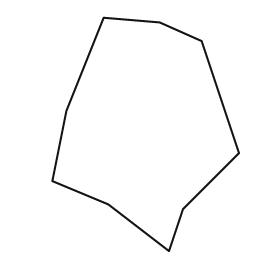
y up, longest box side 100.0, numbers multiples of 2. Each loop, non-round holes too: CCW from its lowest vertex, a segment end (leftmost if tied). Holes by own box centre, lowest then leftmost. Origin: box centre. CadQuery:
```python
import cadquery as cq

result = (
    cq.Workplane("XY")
    .moveTo(10.0, -50.0)
    .lineTo(16.0, -32.0)
    .lineTo(40.0, -8.0)
    .lineTo(24.0, 40.0)
    .lineTo(6.0, 48.0)
    .lineTo(-18.0, 50.0)
    .lineTo(-34.0, 10.0)
    .lineTo(-40.0, -20.0)
    .lineTo(-16.0, -30.0)
    .close()
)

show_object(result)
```